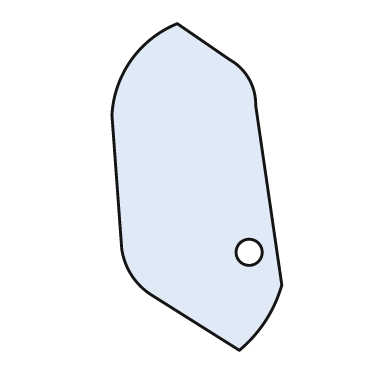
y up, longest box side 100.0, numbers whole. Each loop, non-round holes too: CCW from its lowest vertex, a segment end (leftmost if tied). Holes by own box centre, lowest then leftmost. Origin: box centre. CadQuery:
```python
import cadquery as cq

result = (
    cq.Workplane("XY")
    .moveTo(13.0, -50.0)
    .threePointArc((21.0, -41.0), (26.0, -30.0))
    .lineTo(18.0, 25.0)
    .threePointArc((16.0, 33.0), (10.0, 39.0))
    .lineTo(-6.0, 50.0)
    .threePointArc((-20.0, 39.0), (-26.0, 22.0))
    .lineTo(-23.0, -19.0)
    .threePointArc((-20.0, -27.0), (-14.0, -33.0))
    .close()
    .moveTo(16.0, -20.0)
    .circle(4.0)
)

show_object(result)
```